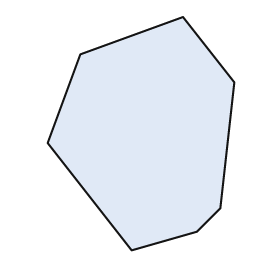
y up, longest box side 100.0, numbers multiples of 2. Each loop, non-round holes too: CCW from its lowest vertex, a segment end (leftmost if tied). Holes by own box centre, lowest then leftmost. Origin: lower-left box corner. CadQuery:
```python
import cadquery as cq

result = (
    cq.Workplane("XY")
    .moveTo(36.0, 0.0)
    .lineTo(64.0, 8.0)
    .lineTo(74.0, 18.0)
    .lineTo(80.0, 72.0)
    .lineTo(58.0, 100.0)
    .lineTo(14.0, 84.0)
    .lineTo(0.0, 46.0)
    .close()
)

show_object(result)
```